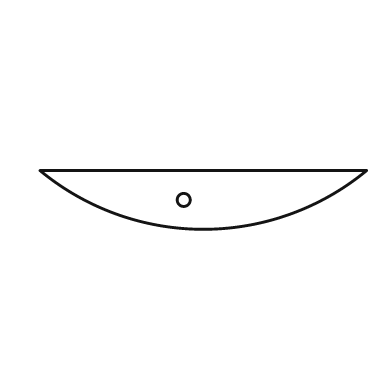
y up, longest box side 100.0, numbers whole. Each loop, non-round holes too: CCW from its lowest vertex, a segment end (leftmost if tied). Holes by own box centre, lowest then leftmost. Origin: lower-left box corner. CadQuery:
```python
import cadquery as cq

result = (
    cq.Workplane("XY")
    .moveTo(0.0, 18.0)
    .threePointArc((50.0, 0.0), (100.0, 18.0))
    .close()
    .moveTo(44.0, 9.0)
    .circle(2.0)
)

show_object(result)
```